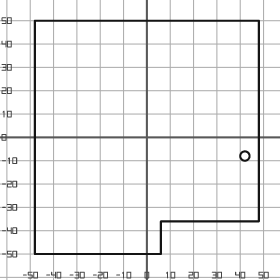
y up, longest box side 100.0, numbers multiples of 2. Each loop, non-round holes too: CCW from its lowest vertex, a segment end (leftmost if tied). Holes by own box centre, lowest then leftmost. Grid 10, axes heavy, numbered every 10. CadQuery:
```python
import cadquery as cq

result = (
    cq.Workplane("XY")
    .moveTo(-48.0, -50.0)
    .lineTo(6.0, -50.0)
    .lineTo(6.0, -36.0)
    .lineTo(48.0, -36.0)
    .lineTo(48.0, 50.0)
    .lineTo(-48.0, 50.0)
    .close()
    .moveTo(42.0, -8.0)
    .circle(2.0)
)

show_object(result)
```